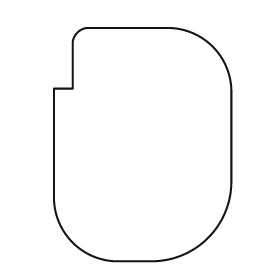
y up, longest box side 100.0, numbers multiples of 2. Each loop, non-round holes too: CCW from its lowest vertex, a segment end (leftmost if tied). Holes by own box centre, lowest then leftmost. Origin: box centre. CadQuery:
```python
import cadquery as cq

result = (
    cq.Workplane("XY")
    .moveTo(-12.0, -50.0)
    .lineTo(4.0, -50.0)
    .threePointArc((28.0, -40.0), (38.0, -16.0))
    .lineTo(38.0, 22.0)
    .threePointArc((30.0, 42.0), (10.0, 50.0))
    .lineTo(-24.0, 50.0)
    .threePointArc((-28.0, 48.0), (-30.0, 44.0))
    .lineTo(-30.0, 24.0)
    .lineTo(-38.0, 24.0)
    .lineTo(-38.0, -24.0)
    .threePointArc((-30.0, -42.0), (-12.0, -50.0))
    .close()
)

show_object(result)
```